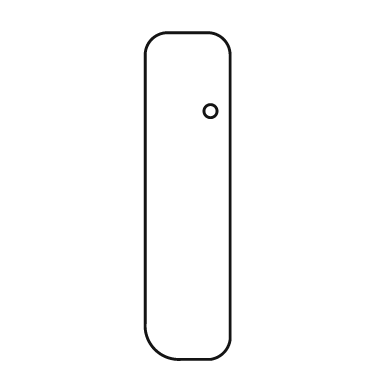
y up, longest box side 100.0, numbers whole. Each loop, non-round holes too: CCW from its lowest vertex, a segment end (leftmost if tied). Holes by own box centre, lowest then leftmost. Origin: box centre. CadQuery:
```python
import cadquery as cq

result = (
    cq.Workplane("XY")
    .moveTo(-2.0, -50.0)
    .lineTo(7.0, -50.0)
    .threePointArc((11.0, -48.0), (13.0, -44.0))
    .lineTo(13.0, 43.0)
    .threePointArc((11.0, 48.0), (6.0, 50.0))
    .lineTo(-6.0, 50.0)
    .threePointArc((-11.0, 48.0), (-13.0, 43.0))
    .lineTo(-13.0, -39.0)
    .threePointArc((-10.0, -47.0), (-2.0, -50.0))
    .close()
    .moveTo(7.0, 26.0)
    .circle(2.0)
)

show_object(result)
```